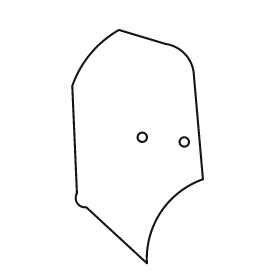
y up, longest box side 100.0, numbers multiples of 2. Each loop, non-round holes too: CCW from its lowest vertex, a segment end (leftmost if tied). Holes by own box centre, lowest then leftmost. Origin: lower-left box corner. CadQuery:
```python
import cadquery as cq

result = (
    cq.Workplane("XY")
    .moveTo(32.0, 0.0)
    .threePointArc((38.0, 22.0), (56.0, 36.0))
    .lineTo(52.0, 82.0)
    .threePointArc((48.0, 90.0), (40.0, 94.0))
    .lineTo(20.0, 100.0)
    .threePointArc((8.0, 90.0), (0.0, 76.0))
    .lineTo(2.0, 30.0)
    .threePointArc((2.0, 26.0), (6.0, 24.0))
    .close()
    .moveTo(48.0, 52.0)
    .circle(2.0)
    .moveTo(30.0, 54.0)
    .circle(2.0)
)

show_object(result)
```